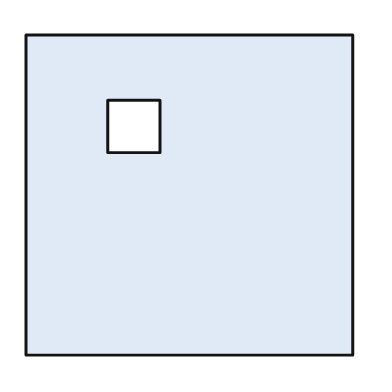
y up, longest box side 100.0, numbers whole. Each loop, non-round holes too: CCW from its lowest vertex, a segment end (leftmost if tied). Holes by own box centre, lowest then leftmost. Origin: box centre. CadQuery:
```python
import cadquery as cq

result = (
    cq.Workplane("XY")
    .moveTo(-50.0, -49.0)
    .lineTo(50.0, -49.0)
    .lineTo(50.0, 49.0)
    .lineTo(-50.0, 49.0)
    .close()
    .moveTo(-25.0, 13.0)
    .lineTo(-9.0, 13.0)
    .lineTo(-9.0, 29.0)
    .lineTo(-25.0, 29.0)
    .close()
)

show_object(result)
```